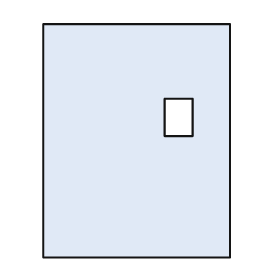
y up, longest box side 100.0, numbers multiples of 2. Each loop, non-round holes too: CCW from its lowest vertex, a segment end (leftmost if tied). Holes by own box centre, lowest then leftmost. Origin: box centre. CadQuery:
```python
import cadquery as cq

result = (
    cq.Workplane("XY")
    .moveTo(-40.0, -50.0)
    .lineTo(40.0, -50.0)
    .lineTo(40.0, 50.0)
    .lineTo(-40.0, 50.0)
    .close()
    .moveTo(12.0, 2.0)
    .lineTo(24.0, 2.0)
    .lineTo(24.0, 18.0)
    .lineTo(12.0, 18.0)
    .close()
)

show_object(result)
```